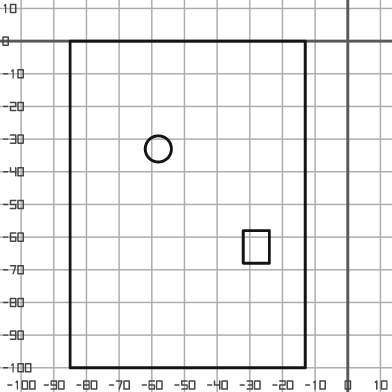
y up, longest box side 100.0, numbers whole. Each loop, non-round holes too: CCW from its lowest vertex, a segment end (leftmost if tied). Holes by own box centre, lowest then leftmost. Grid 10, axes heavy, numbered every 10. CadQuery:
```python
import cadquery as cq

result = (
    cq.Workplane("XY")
    .moveTo(-85.0, -100.0)
    .lineTo(-13.0, -100.0)
    .lineTo(-13.0, 0.0)
    .lineTo(-85.0, 0.0)
    .close()
    .moveTo(-32.0, -68.0)
    .lineTo(-24.0, -68.0)
    .lineTo(-24.0, -58.0)
    .lineTo(-32.0, -58.0)
    .close()
    .moveTo(-58.0, -33.0)
    .circle(4.0)
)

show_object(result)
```